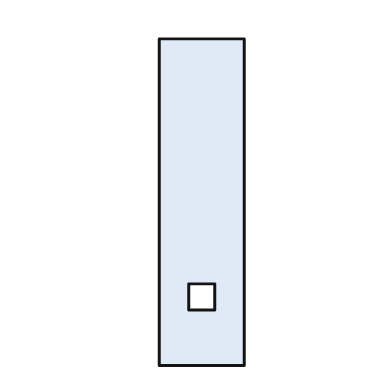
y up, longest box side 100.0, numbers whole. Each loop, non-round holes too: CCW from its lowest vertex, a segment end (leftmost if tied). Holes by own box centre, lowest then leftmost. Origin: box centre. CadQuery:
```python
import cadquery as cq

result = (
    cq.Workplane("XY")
    .moveTo(-13.0, -50.0)
    .lineTo(13.0, -50.0)
    .lineTo(13.0, 50.0)
    .lineTo(-13.0, 50.0)
    .close()
    .moveTo(-4.0, -33.0)
    .lineTo(4.0, -33.0)
    .lineTo(4.0, -25.0)
    .lineTo(-4.0, -25.0)
    .close()
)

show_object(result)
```